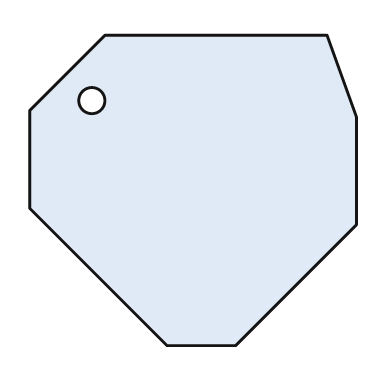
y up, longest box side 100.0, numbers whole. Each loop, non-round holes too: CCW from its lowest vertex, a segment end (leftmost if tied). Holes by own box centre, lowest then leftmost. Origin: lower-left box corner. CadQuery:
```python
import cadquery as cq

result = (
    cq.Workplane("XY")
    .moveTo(42.0, 0.0)
    .lineTo(63.0, 0.0)
    .lineTo(100.0, 37.0)
    .lineTo(100.0, 70.0)
    .lineTo(91.0, 95.0)
    .lineTo(23.0, 95.0)
    .lineTo(0.0, 72.0)
    .lineTo(0.0, 42.0)
    .close()
    .moveTo(19.0, 75.0)
    .circle(4.0)
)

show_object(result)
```